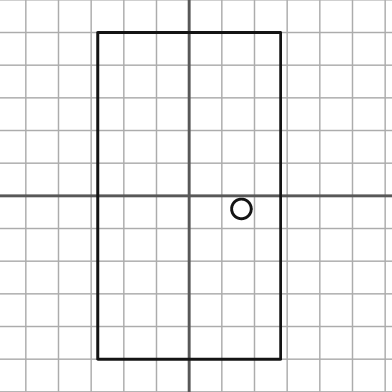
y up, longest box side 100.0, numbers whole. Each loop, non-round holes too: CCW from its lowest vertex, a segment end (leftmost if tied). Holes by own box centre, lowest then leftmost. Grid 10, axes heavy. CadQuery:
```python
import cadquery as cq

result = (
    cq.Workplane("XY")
    .moveTo(-28.0, -50.0)
    .lineTo(28.0, -50.0)
    .lineTo(28.0, 50.0)
    .lineTo(-28.0, 50.0)
    .close()
    .moveTo(16.0, -4.0)
    .circle(3.0)
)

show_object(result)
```